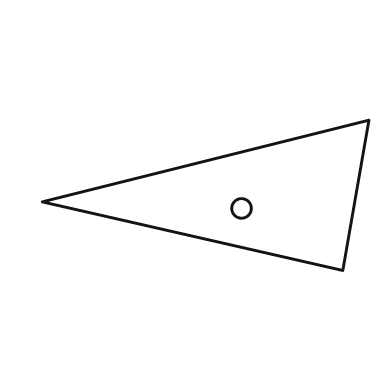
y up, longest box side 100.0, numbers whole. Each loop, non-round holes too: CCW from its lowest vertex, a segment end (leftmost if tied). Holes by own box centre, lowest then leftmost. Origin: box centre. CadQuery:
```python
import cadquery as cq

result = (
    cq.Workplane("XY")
    .moveTo(42.0, -23.0)
    .lineTo(50.0, 23.0)
    .lineTo(-50.0, -2.0)
    .close()
    .moveTo(11.0, -4.0)
    .circle(3.0)
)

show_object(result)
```